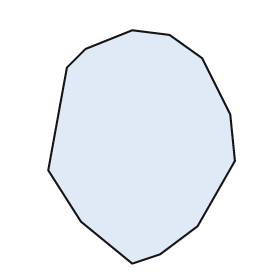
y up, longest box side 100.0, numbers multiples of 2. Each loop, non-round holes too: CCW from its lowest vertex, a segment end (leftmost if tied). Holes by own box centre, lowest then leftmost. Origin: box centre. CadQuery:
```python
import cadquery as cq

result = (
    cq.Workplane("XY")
    .moveTo(-4.0, -50.0)
    .lineTo(8.0, -46.0)
    .lineTo(24.0, -34.0)
    .lineTo(40.0, -6.0)
    .lineTo(38.0, 14.0)
    .lineTo(26.0, 38.0)
    .lineTo(12.0, 48.0)
    .lineTo(-4.0, 50.0)
    .lineTo(-24.0, 42.0)
    .lineTo(-32.0, 34.0)
    .lineTo(-40.0, -10.0)
    .lineTo(-26.0, -32.0)
    .close()
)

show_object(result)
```